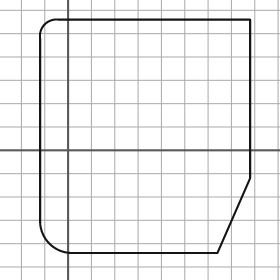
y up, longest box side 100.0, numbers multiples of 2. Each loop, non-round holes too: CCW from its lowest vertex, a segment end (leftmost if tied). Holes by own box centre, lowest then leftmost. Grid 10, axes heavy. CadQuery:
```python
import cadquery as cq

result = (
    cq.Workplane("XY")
    .moveTo(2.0, -44.0)
    .lineTo(64.0, -44.0)
    .lineTo(78.0, -12.0)
    .lineTo(78.0, 56.0)
    .lineTo(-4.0, 56.0)
    .threePointArc((-10.0, 54.0), (-12.0, 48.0))
    .lineTo(-12.0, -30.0)
    .threePointArc((-8.0, -40.0), (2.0, -44.0))
    .close()
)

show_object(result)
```